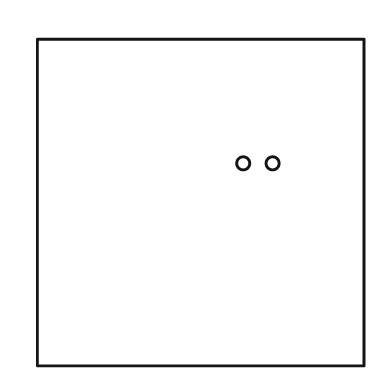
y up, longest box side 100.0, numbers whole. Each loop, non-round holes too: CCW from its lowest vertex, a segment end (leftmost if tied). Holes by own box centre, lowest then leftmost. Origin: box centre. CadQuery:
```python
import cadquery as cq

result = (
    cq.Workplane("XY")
    .moveTo(-50.0, -50.0)
    .lineTo(50.0, -50.0)
    .lineTo(50.0, 50.0)
    .lineTo(-50.0, 50.0)
    .close()
    .moveTo(13.0, 12.0)
    .circle(2.0)
    .moveTo(22.0, 12.0)
    .circle(2.0)
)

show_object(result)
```